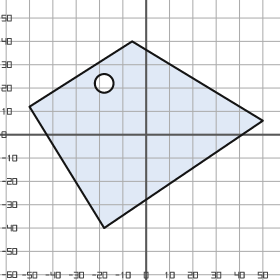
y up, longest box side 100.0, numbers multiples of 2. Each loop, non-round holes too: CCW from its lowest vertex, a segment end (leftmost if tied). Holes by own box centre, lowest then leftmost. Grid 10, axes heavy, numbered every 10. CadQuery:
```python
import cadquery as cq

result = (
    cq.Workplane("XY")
    .moveTo(-18.0, -40.0)
    .lineTo(50.0, 6.0)
    .lineTo(-6.0, 40.0)
    .lineTo(-50.0, 12.0)
    .close()
    .moveTo(-18.0, 22.0)
    .circle(4.0)
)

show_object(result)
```